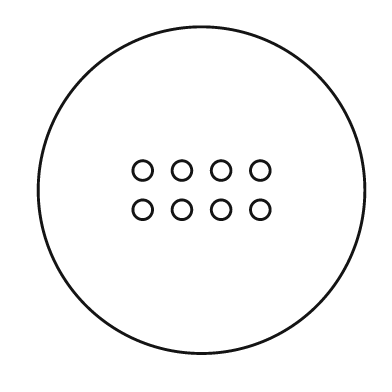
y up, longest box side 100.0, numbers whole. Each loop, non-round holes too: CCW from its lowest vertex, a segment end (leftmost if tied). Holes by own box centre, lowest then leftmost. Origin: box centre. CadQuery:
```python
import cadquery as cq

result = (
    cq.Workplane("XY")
    .moveTo(0.0, 0.0)
    .circle(50.0)
    .moveTo(-18.0, -6.0)
    .circle(3.0)
    .moveTo(-6.0, -6.0)
    .circle(3.0)
    .moveTo(6.0, -6.0)
    .circle(3.0)
    .moveTo(18.0, -6.0)
    .circle(3.0)
    .moveTo(-18.0, 6.0)
    .circle(3.0)
    .moveTo(-6.0, 6.0)
    .circle(3.0)
    .moveTo(6.0, 6.0)
    .circle(3.0)
    .moveTo(18.0, 6.0)
    .circle(3.0)
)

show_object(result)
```